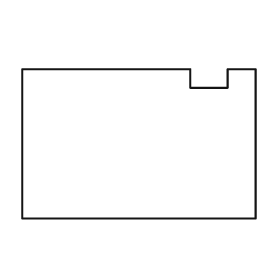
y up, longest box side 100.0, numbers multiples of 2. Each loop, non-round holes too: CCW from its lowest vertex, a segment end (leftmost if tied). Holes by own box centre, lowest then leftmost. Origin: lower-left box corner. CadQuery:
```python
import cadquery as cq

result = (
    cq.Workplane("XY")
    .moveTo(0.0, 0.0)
    .lineTo(100.0, 0.0)
    .lineTo(100.0, 64.0)
    .lineTo(88.0, 64.0)
    .lineTo(88.0, 56.0)
    .lineTo(72.0, 56.0)
    .lineTo(72.0, 64.0)
    .lineTo(0.0, 64.0)
    .close()
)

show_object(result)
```